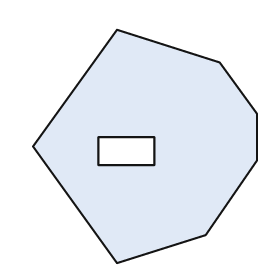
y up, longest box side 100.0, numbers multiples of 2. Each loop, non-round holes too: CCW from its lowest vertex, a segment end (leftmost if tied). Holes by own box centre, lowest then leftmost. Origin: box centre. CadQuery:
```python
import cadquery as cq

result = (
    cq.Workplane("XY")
    .moveTo(-12.0, -50.0)
    .lineTo(26.0, -38.0)
    .lineTo(48.0, -6.0)
    .lineTo(48.0, 14.0)
    .lineTo(32.0, 36.0)
    .lineTo(-12.0, 50.0)
    .lineTo(-48.0, 0.0)
    .close()
    .moveTo(-20.0, -8.0)
    .lineTo(4.0, -8.0)
    .lineTo(4.0, 4.0)
    .lineTo(-20.0, 4.0)
    .close()
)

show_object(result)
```